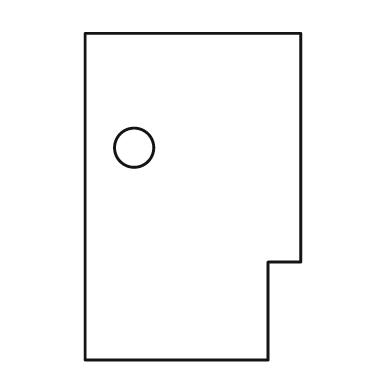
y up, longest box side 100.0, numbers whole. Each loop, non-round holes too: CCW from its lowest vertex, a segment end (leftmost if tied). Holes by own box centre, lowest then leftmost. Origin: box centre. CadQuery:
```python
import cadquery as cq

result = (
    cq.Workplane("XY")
    .moveTo(-33.0, -50.0)
    .lineTo(23.0, -50.0)
    .lineTo(23.0, -20.0)
    .lineTo(33.0, -20.0)
    .lineTo(33.0, 50.0)
    .lineTo(-33.0, 50.0)
    .close()
    .moveTo(-18.0, 15.0)
    .circle(6.0)
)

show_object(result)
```